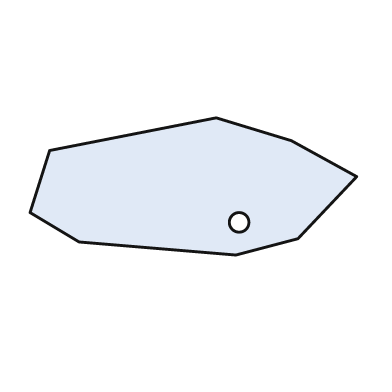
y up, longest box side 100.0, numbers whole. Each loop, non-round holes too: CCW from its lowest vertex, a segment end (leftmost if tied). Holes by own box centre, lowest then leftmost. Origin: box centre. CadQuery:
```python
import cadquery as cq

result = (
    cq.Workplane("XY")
    .moveTo(13.0, -21.0)
    .lineTo(32.0, -16.0)
    .lineTo(50.0, 3.0)
    .lineTo(30.0, 14.0)
    .lineTo(7.0, 21.0)
    .lineTo(-44.0, 11.0)
    .lineTo(-50.0, -8.0)
    .lineTo(-35.0, -17.0)
    .close()
    .moveTo(14.0, -11.0)
    .circle(3.0)
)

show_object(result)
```